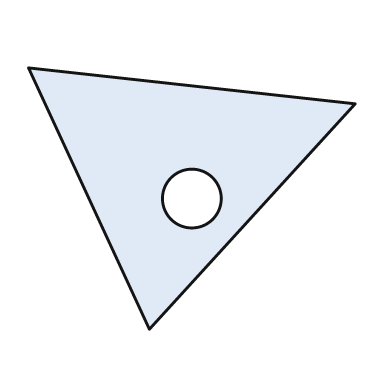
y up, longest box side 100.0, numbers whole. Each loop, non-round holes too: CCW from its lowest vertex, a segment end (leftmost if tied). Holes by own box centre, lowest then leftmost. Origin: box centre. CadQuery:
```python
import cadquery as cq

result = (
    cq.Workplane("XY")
    .moveTo(-13.0, -40.0)
    .lineTo(50.0, 29.0)
    .lineTo(-50.0, 40.0)
    .close()
    .moveTo(0.0, 0.0)
    .circle(9.0)
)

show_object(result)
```